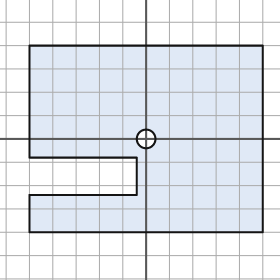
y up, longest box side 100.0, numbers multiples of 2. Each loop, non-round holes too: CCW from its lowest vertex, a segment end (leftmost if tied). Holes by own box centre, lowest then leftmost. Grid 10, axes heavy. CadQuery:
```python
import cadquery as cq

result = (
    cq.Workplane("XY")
    .moveTo(-50.0, -40.0)
    .lineTo(50.0, -40.0)
    .lineTo(50.0, 40.0)
    .lineTo(-50.0, 40.0)
    .lineTo(-50.0, -8.0)
    .lineTo(-4.0, -8.0)
    .lineTo(-4.0, -24.0)
    .lineTo(-50.0, -24.0)
    .close()
    .moveTo(0.0, 0.0)
    .circle(4.0)
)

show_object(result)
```